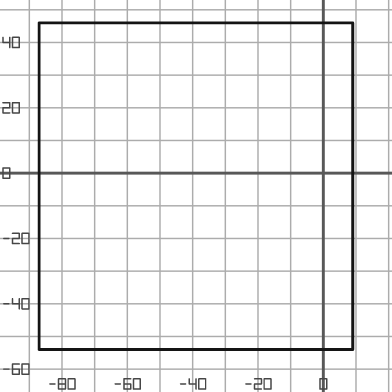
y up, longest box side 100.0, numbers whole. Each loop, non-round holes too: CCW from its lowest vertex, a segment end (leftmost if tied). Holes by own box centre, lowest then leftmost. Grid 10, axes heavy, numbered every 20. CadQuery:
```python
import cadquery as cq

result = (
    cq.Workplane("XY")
    .moveTo(-87.0, -54.0)
    .lineTo(9.0, -54.0)
    .lineTo(9.0, 46.0)
    .lineTo(-87.0, 46.0)
    .close()
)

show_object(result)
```